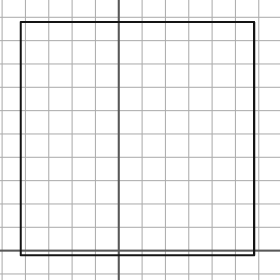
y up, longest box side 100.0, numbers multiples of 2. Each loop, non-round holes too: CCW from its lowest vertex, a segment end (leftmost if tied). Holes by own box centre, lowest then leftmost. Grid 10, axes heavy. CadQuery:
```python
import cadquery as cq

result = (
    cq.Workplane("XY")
    .moveTo(-42.0, -2.0)
    .lineTo(58.0, -2.0)
    .lineTo(58.0, 98.0)
    .lineTo(-42.0, 98.0)
    .close()
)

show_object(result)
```